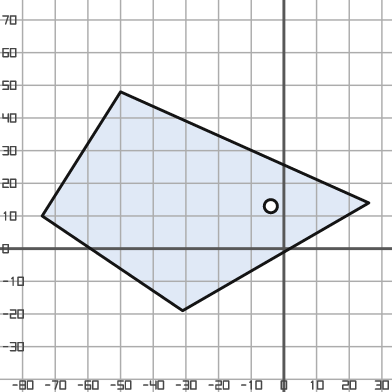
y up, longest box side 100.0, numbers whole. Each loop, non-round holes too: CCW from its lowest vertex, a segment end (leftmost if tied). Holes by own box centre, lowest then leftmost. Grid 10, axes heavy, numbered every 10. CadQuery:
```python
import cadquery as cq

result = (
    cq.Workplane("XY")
    .moveTo(-31.0, -19.0)
    .lineTo(26.0, 14.0)
    .lineTo(-50.0, 48.0)
    .lineTo(-74.0, 10.0)
    .close()
    .moveTo(-4.0, 13.0)
    .circle(2.0)
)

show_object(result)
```